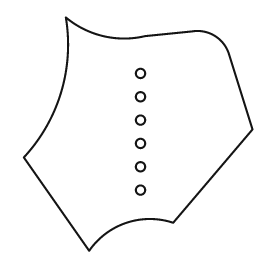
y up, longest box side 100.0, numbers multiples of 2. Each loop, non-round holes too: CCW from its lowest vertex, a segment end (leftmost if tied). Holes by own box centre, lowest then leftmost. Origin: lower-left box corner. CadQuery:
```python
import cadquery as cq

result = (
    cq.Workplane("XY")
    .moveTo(28.0, 0.0)
    .threePointArc((44.0, 12.0), (64.0, 12.0))
    .lineTo(98.0, 52.0)
    .lineTo(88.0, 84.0)
    .threePointArc((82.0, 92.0), (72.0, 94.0))
    .lineTo(52.0, 92.0)
    .threePointArc((34.0, 92.0), (18.0, 100.0))
    .threePointArc((16.0, 68.0), (0.0, 40.0))
    .close()
    .moveTo(50.0, 26.0)
    .circle(2.0)
    .moveTo(50.0, 36.0)
    .circle(2.0)
    .moveTo(50.0, 46.0)
    .circle(2.0)
    .moveTo(50.0, 56.0)
    .circle(2.0)
    .moveTo(50.0, 66.0)
    .circle(2.0)
    .moveTo(50.0, 76.0)
    .circle(2.0)
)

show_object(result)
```